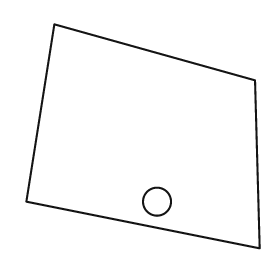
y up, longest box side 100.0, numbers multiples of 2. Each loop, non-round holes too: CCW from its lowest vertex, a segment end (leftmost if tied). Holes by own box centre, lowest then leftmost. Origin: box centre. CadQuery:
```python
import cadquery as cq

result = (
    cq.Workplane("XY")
    .moveTo(50.0, -48.0)
    .lineTo(48.0, 24.0)
    .lineTo(-38.0, 48.0)
    .lineTo(-50.0, -28.0)
    .close()
    .moveTo(6.0, -28.0)
    .circle(6.0)
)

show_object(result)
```